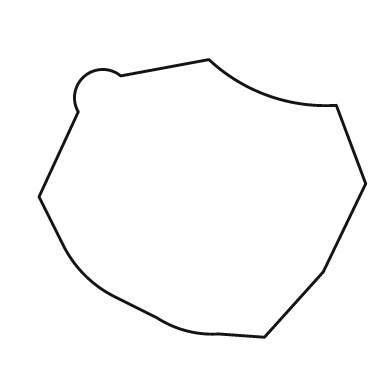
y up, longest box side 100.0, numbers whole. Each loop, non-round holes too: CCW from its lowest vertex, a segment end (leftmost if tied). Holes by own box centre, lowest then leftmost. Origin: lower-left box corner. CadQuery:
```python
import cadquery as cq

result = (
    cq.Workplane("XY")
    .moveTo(69.0, 0.0)
    .lineTo(87.0, 20.0)
    .lineTo(100.0, 47.0)
    .lineTo(91.0, 71.0)
    .threePointArc((70.0, 74.0), (52.0, 85.0))
    .lineTo(25.0, 80.0)
    .threePointArc((14.0, 80.0), (12.0, 69.0))
    .lineTo(0.0, 43.0)
    .lineTo(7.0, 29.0)
    .threePointArc((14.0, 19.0), (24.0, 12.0))
    .lineTo(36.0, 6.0)
    .threePointArc((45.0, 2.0), (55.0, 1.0))
    .close()
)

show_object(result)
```